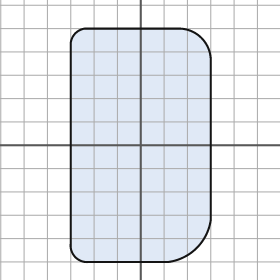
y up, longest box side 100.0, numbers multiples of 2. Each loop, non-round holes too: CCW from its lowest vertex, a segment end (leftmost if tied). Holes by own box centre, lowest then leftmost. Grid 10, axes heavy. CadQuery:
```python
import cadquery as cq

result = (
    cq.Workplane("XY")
    .moveTo(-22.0, -50.0)
    .lineTo(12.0, -50.0)
    .threePointArc((24.0, -44.0), (30.0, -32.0))
    .lineTo(30.0, 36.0)
    .threePointArc((26.0, 46.0), (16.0, 50.0))
    .lineTo(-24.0, 50.0)
    .threePointArc((-28.0, 48.0), (-30.0, 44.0))
    .lineTo(-30.0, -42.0)
    .threePointArc((-28.0, -48.0), (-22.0, -50.0))
    .close()
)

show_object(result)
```